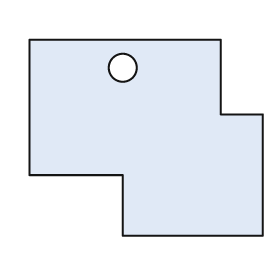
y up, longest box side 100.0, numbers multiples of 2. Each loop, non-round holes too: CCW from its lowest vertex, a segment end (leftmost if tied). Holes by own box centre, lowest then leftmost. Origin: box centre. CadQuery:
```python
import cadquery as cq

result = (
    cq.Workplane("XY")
    .moveTo(-10.0, -42.0)
    .lineTo(50.0, -42.0)
    .lineTo(50.0, 10.0)
    .lineTo(32.0, 10.0)
    .lineTo(32.0, 42.0)
    .lineTo(-50.0, 42.0)
    .lineTo(-50.0, -16.0)
    .lineTo(-10.0, -16.0)
    .close()
    .moveTo(-10.0, 30.0)
    .circle(6.0)
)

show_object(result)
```